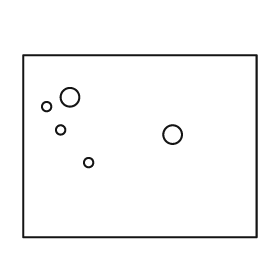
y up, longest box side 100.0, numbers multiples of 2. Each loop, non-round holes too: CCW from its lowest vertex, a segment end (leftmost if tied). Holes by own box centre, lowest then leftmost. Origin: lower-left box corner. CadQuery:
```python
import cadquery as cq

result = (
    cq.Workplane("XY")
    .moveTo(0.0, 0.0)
    .lineTo(100.0, 0.0)
    .lineTo(100.0, 78.0)
    .lineTo(0.0, 78.0)
    .close()
    .moveTo(28.0, 32.0)
    .circle(2.0)
    .moveTo(64.0, 44.0)
    .circle(4.0)
    .moveTo(16.0, 46.0)
    .circle(2.0)
    .moveTo(10.0, 56.0)
    .circle(2.0)
    .moveTo(20.0, 60.0)
    .circle(4.0)
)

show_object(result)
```